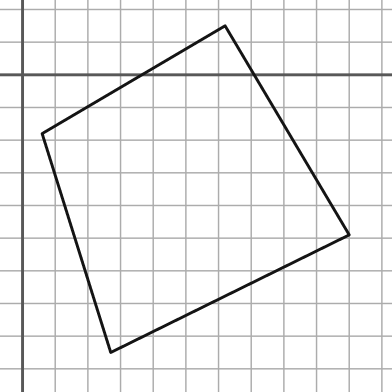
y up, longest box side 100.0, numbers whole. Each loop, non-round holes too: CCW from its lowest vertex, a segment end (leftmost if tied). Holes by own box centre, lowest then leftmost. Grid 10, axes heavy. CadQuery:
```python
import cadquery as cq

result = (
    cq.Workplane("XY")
    .moveTo(27.0, -85.0)
    .lineTo(100.0, -49.0)
    .lineTo(62.0, 15.0)
    .lineTo(6.0, -18.0)
    .close()
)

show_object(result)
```